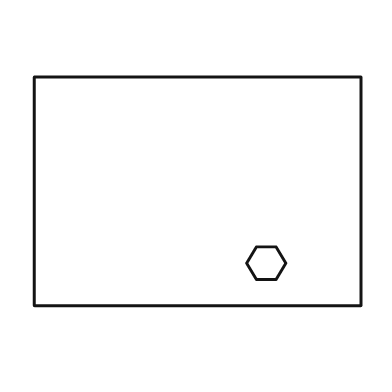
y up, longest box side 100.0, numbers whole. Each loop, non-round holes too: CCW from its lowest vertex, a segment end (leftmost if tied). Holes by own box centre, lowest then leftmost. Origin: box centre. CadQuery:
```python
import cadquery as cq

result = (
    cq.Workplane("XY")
    .moveTo(-50.0, -35.0)
    .lineTo(50.0, -35.0)
    .lineTo(50.0, 35.0)
    .lineTo(-50.0, 35.0)
    .close()
    .moveTo(18.0, -27.0)
    .lineTo(24.0, -27.0)
    .lineTo(27.0, -22.0)
    .lineTo(24.0, -17.0)
    .lineTo(18.0, -17.0)
    .lineTo(15.0, -22.0)
    .close()
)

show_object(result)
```